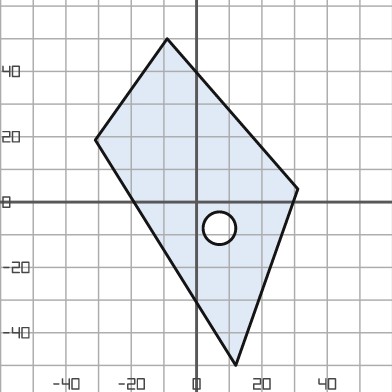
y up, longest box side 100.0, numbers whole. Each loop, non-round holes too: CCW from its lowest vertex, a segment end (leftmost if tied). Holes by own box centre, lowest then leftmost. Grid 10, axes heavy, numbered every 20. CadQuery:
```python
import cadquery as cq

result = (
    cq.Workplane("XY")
    .moveTo(12.0, -50.0)
    .lineTo(31.0, 4.0)
    .lineTo(-9.0, 50.0)
    .lineTo(-31.0, 19.0)
    .close()
    .moveTo(7.0, -8.0)
    .circle(5.0)
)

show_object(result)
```